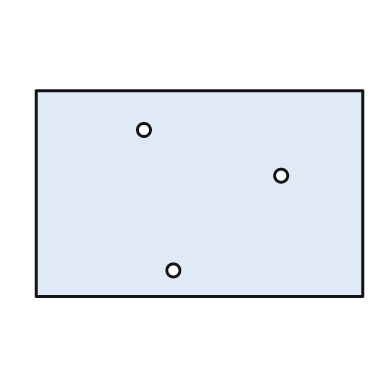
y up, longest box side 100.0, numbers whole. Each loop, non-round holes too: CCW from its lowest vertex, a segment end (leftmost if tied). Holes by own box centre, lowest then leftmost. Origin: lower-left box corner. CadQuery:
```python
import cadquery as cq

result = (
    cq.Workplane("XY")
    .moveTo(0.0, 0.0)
    .lineTo(100.0, 0.0)
    .lineTo(100.0, 63.0)
    .lineTo(0.0, 63.0)
    .close()
    .moveTo(42.0, 8.0)
    .circle(2.0)
    .moveTo(75.0, 37.0)
    .circle(2.0)
    .moveTo(33.0, 51.0)
    .circle(2.0)
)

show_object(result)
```